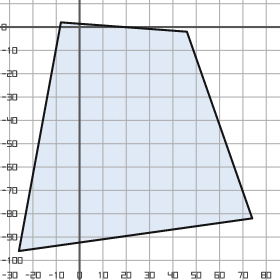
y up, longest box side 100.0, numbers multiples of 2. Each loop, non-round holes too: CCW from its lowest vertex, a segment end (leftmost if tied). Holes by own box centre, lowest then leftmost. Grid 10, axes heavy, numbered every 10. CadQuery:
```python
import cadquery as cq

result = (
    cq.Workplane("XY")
    .moveTo(-26.0, -96.0)
    .lineTo(74.0, -82.0)
    .lineTo(46.0, -2.0)
    .lineTo(-8.0, 2.0)
    .close()
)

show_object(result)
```